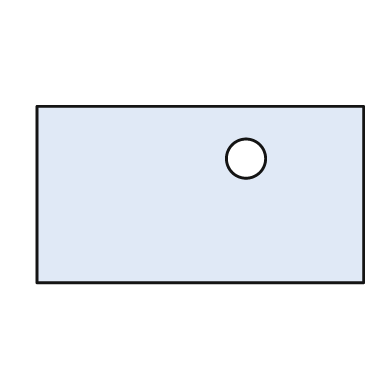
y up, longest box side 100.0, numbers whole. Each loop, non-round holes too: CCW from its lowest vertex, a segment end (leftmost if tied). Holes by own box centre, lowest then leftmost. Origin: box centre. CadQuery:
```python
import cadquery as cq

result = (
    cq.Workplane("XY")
    .moveTo(-50.0, -27.0)
    .lineTo(50.0, -27.0)
    .lineTo(50.0, 27.0)
    .lineTo(-50.0, 27.0)
    .close()
    .moveTo(14.0, 11.0)
    .circle(6.0)
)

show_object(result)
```